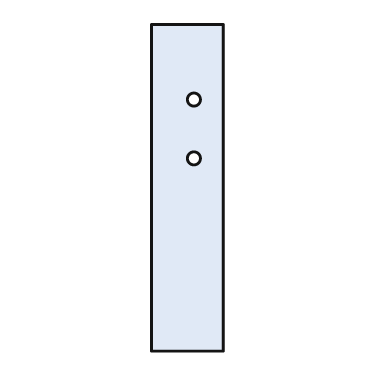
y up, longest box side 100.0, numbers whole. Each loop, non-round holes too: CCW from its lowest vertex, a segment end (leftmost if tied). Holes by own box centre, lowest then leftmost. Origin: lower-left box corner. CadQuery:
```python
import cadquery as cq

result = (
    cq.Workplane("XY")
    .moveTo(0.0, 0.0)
    .lineTo(22.0, 0.0)
    .lineTo(22.0, 100.0)
    .lineTo(0.0, 100.0)
    .close()
    .moveTo(13.0, 59.0)
    .circle(2.0)
    .moveTo(13.0, 77.0)
    .circle(2.0)
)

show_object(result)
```